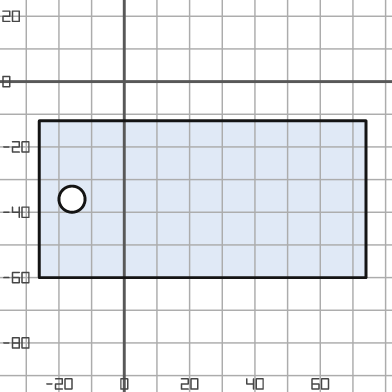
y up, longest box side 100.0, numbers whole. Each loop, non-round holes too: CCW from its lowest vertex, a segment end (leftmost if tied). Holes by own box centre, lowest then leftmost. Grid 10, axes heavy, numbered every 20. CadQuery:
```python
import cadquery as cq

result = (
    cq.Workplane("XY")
    .moveTo(-26.0, -60.0)
    .lineTo(74.0, -60.0)
    .lineTo(74.0, -12.0)
    .lineTo(-26.0, -12.0)
    .close()
    .moveTo(-16.0, -36.0)
    .circle(4.0)
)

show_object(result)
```